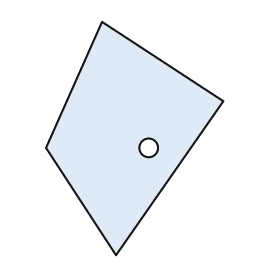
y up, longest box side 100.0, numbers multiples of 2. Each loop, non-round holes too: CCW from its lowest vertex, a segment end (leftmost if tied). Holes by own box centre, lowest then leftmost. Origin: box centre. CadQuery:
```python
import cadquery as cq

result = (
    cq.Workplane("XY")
    .moveTo(-8.0, -50.0)
    .lineTo(38.0, 16.0)
    .lineTo(-14.0, 50.0)
    .lineTo(-38.0, -4.0)
    .close()
    .moveTo(6.0, -4.0)
    .circle(4.0)
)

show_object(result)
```